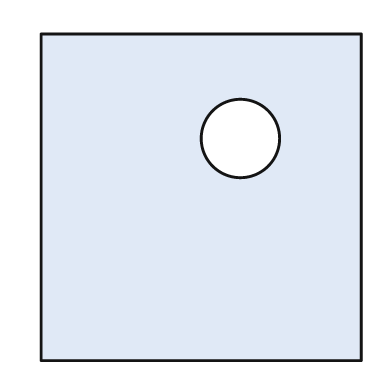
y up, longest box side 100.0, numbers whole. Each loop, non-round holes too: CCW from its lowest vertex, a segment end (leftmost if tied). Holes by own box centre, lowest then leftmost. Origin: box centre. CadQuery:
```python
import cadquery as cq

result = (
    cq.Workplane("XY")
    .moveTo(-49.0, -50.0)
    .lineTo(49.0, -50.0)
    .lineTo(49.0, 50.0)
    .lineTo(-49.0, 50.0)
    .close()
    .moveTo(12.0, 18.0)
    .circle(12.0)
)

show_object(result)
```